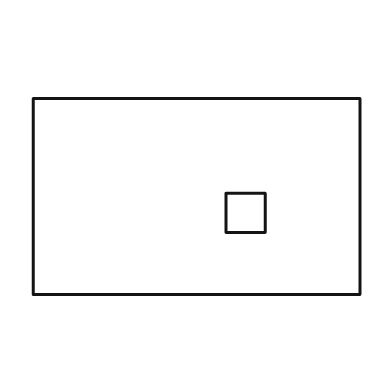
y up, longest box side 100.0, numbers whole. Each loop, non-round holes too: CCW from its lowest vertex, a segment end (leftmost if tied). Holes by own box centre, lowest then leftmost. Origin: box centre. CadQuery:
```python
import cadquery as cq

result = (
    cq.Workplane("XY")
    .moveTo(-50.0, -30.0)
    .lineTo(50.0, -30.0)
    .lineTo(50.0, 30.0)
    .lineTo(-50.0, 30.0)
    .close()
    .moveTo(9.0, -11.0)
    .lineTo(21.0, -11.0)
    .lineTo(21.0, 1.0)
    .lineTo(9.0, 1.0)
    .close()
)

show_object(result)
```